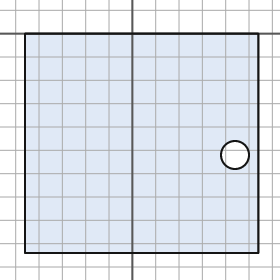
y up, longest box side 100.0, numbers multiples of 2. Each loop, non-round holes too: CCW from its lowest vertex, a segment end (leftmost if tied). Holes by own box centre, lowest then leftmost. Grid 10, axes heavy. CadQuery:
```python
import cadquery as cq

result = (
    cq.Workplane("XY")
    .moveTo(-46.0, -94.0)
    .lineTo(54.0, -94.0)
    .lineTo(54.0, 0.0)
    .lineTo(-46.0, 0.0)
    .close()
    .moveTo(44.0, -52.0)
    .circle(6.0)
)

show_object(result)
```